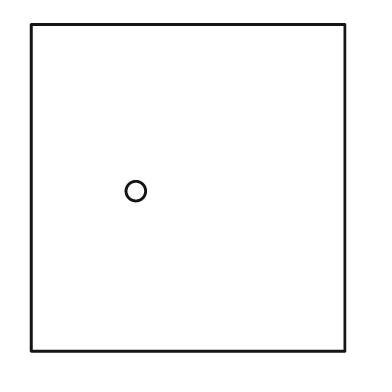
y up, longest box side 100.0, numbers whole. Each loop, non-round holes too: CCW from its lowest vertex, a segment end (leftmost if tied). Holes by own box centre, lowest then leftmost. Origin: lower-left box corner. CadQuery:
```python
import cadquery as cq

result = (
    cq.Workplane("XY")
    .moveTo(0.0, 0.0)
    .lineTo(96.0, 0.0)
    .lineTo(96.0, 100.0)
    .lineTo(0.0, 100.0)
    .close()
    .moveTo(32.0, 49.0)
    .circle(3.0)
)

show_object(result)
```